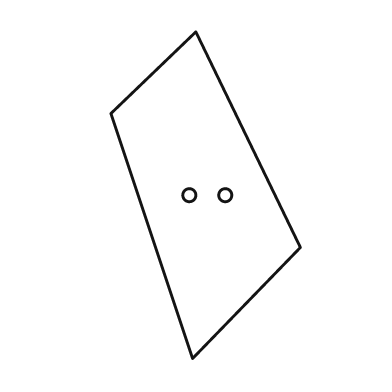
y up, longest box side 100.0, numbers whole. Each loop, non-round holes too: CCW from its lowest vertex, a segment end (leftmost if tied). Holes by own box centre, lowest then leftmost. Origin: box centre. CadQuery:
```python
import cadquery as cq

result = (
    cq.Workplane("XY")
    .moveTo(-4.0, -50.0)
    .lineTo(29.0, -16.0)
    .lineTo(-3.0, 50.0)
    .lineTo(-29.0, 25.0)
    .close()
    .moveTo(-5.0, 0.0)
    .circle(2.0)
    .moveTo(6.0, 0.0)
    .circle(2.0)
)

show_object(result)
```